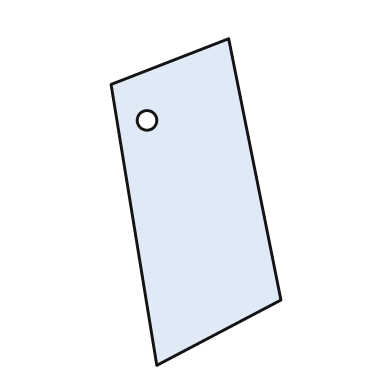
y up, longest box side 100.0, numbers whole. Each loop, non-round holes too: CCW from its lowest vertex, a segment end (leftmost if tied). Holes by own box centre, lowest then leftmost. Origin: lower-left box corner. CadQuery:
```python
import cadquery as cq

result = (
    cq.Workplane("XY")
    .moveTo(14.0, 0.0)
    .lineTo(52.0, 20.0)
    .lineTo(36.0, 100.0)
    .lineTo(0.0, 86.0)
    .close()
    .moveTo(11.0, 75.0)
    .circle(3.0)
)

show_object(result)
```